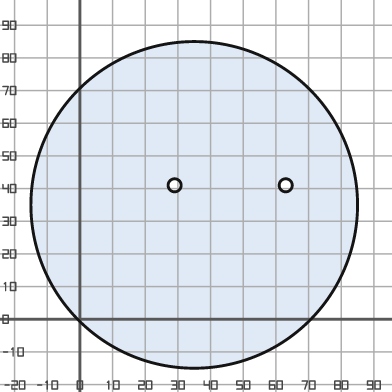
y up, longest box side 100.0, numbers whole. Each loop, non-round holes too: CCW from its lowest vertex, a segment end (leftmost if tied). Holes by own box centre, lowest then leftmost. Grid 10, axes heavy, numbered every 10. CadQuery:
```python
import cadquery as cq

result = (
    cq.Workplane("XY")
    .moveTo(35.0, 35.0)
    .circle(50.0)
    .moveTo(29.0, 41.0)
    .circle(2.0)
    .moveTo(63.0, 41.0)
    .circle(2.0)
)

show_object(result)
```